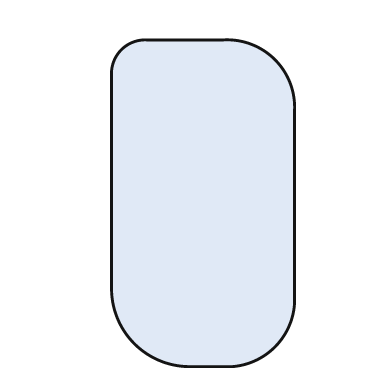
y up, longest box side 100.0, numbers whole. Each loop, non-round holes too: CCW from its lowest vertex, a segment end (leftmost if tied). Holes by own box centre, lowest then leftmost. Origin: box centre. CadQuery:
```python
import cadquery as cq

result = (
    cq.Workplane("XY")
    .moveTo(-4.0, -50.0)
    .lineTo(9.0, -50.0)
    .threePointArc((22.0, -44.0), (28.0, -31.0))
    .lineTo(28.0, 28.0)
    .threePointArc((22.0, 44.0), (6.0, 50.0))
    .lineTo(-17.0, 50.0)
    .threePointArc((-25.0, 47.0), (-28.0, 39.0))
    .lineTo(-28.0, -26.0)
    .threePointArc((-21.0, -43.0), (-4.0, -50.0))
    .close()
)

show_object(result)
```